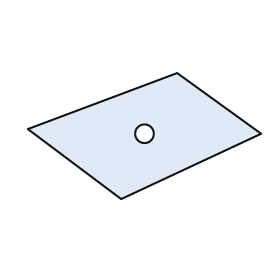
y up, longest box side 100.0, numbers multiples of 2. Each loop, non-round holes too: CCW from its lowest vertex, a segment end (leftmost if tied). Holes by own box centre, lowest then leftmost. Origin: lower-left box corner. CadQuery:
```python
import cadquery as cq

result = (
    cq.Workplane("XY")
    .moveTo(40.0, 0.0)
    .lineTo(100.0, 28.0)
    .lineTo(64.0, 54.0)
    .lineTo(0.0, 30.0)
    .close()
    .moveTo(50.0, 28.0)
    .circle(4.0)
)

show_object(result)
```